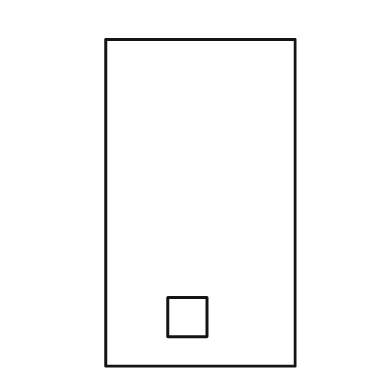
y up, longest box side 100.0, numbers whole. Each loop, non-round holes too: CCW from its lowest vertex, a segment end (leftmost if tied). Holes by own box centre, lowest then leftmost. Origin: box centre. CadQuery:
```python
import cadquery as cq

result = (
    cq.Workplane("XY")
    .moveTo(-29.0, -50.0)
    .lineTo(29.0, -50.0)
    .lineTo(29.0, 50.0)
    .lineTo(-29.0, 50.0)
    .close()
    .moveTo(-10.0, -41.0)
    .lineTo(2.0, -41.0)
    .lineTo(2.0, -29.0)
    .lineTo(-10.0, -29.0)
    .close()
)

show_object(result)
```